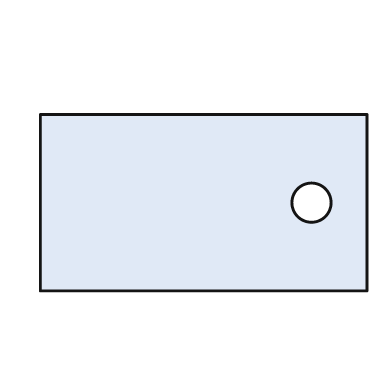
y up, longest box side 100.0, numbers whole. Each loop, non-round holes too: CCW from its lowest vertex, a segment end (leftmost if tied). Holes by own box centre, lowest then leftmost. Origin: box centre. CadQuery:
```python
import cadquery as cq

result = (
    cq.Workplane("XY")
    .moveTo(-50.0, -27.0)
    .lineTo(50.0, -27.0)
    .lineTo(50.0, 27.0)
    .lineTo(-50.0, 27.0)
    .close()
    .moveTo(33.0, 0.0)
    .circle(6.0)
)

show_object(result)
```